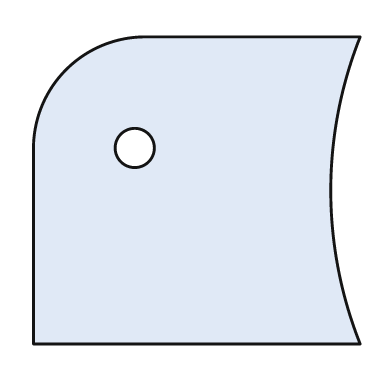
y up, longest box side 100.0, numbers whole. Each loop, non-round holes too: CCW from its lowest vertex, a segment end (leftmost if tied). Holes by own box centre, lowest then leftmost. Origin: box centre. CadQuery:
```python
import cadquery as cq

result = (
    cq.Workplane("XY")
    .moveTo(-50.0, -47.0)
    .lineTo(50.0, -47.0)
    .threePointArc((41.0, 0.0), (50.0, 47.0))
    .lineTo(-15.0, 47.0)
    .threePointArc((-40.0, 37.0), (-50.0, 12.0))
    .close()
    .moveTo(-19.0, 13.0)
    .circle(6.0)
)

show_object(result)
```